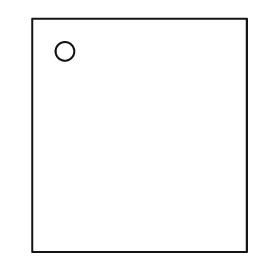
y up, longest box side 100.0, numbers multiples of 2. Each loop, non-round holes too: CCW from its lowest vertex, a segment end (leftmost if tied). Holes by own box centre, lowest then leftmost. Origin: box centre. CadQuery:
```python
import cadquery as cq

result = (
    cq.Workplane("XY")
    .moveTo(-46.0, -50.0)
    .lineTo(46.0, -50.0)
    .lineTo(46.0, 50.0)
    .lineTo(-46.0, 50.0)
    .close()
    .moveTo(-32.0, 36.0)
    .circle(4.0)
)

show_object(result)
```